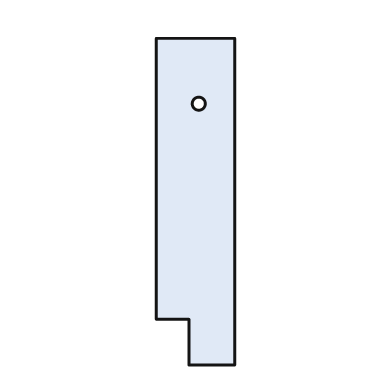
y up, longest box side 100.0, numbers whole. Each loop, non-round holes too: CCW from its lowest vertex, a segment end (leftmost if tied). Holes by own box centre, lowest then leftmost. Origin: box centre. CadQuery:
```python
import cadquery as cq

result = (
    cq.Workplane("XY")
    .moveTo(-2.0, -50.0)
    .lineTo(12.0, -50.0)
    .lineTo(12.0, 50.0)
    .lineTo(-12.0, 50.0)
    .lineTo(-12.0, -36.0)
    .lineTo(-2.0, -36.0)
    .close()
    .moveTo(1.0, 30.0)
    .circle(2.0)
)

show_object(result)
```